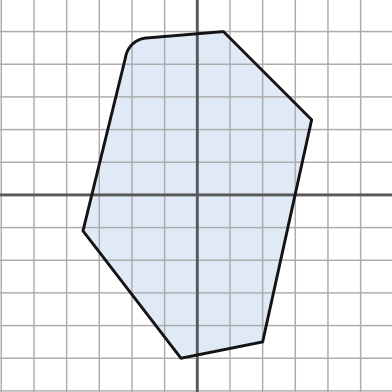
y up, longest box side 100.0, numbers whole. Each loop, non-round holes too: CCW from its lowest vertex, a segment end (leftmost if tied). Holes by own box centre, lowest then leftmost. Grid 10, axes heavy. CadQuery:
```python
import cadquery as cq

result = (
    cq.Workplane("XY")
    .moveTo(-5.0, -50.0)
    .lineTo(20.0, -45.0)
    .lineTo(35.0, 23.0)
    .lineTo(8.0, 50.0)
    .lineTo(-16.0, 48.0)
    .threePointArc((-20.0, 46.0), (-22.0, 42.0))
    .lineTo(-35.0, -11.0)
    .close()
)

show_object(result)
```